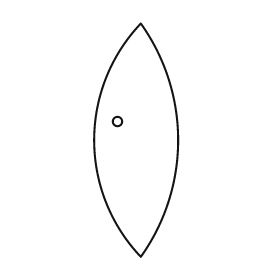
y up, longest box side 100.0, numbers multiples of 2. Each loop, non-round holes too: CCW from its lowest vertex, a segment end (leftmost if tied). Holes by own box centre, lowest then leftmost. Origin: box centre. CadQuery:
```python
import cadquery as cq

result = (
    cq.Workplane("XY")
    .moveTo(2.0, -50.0)
    .threePointArc((18.0, 0.0), (2.0, 50.0))
    .threePointArc((-18.0, 0.0), (2.0, -50.0))
    .close()
    .moveTo(-8.0, 8.0)
    .circle(2.0)
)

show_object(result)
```